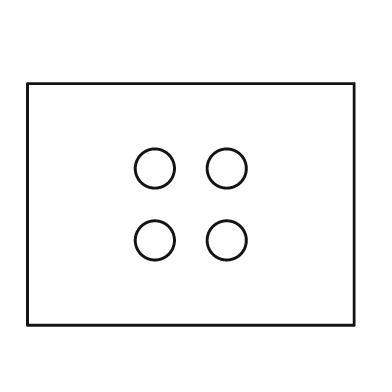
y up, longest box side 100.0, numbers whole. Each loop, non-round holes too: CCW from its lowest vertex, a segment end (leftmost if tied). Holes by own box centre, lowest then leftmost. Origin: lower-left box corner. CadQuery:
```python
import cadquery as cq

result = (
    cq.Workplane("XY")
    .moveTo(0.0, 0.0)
    .lineTo(100.0, 0.0)
    .lineTo(100.0, 74.0)
    .lineTo(0.0, 74.0)
    .close()
    .moveTo(39.0, 26.0)
    .circle(6.0)
    .moveTo(61.0, 26.0)
    .circle(6.0)
    .moveTo(39.0, 48.0)
    .circle(6.0)
    .moveTo(61.0, 48.0)
    .circle(6.0)
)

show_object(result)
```